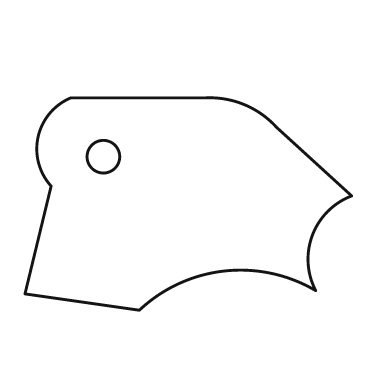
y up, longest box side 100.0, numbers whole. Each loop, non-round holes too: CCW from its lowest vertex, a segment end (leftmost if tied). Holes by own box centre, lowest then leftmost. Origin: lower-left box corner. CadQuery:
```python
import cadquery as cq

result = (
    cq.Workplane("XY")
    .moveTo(35.0, 0.0)
    .threePointArc((61.0, 12.0), (89.0, 6.0))
    .threePointArc((88.0, 23.0), (100.0, 35.0))
    .lineTo(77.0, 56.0)
    .threePointArc((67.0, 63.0), (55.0, 65.0))
    .lineTo(14.0, 65.0)
    .threePointArc((4.0, 53.0), (8.0, 38.0))
    .lineTo(0.0, 5.0)
    .close()
    .moveTo(24.0, 47.0)
    .circle(5.0)
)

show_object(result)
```